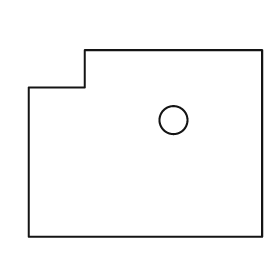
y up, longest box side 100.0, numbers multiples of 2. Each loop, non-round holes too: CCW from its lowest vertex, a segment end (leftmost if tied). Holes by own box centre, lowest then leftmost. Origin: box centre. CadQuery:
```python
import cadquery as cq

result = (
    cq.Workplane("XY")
    .moveTo(-50.0, -40.0)
    .lineTo(50.0, -40.0)
    .lineTo(50.0, 40.0)
    .lineTo(-26.0, 40.0)
    .lineTo(-26.0, 24.0)
    .lineTo(-50.0, 24.0)
    .close()
    .moveTo(12.0, 10.0)
    .circle(6.0)
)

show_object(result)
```